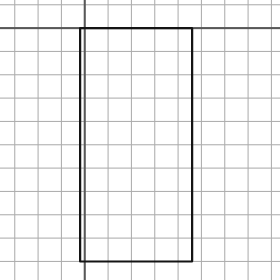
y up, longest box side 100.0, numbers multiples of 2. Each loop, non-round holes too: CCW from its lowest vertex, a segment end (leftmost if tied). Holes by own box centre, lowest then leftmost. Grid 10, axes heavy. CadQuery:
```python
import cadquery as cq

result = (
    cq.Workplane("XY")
    .moveTo(-2.0, -100.0)
    .lineTo(46.0, -100.0)
    .lineTo(46.0, 0.0)
    .lineTo(-2.0, 0.0)
    .close()
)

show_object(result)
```